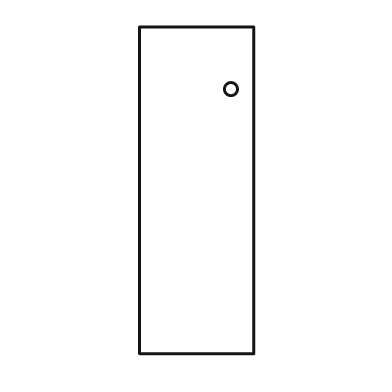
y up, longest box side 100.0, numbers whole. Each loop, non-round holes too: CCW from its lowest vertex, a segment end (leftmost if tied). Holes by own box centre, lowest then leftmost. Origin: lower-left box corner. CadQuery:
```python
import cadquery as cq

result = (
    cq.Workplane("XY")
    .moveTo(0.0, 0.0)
    .lineTo(35.0, 0.0)
    .lineTo(35.0, 100.0)
    .lineTo(0.0, 100.0)
    .close()
    .moveTo(28.0, 81.0)
    .circle(2.0)
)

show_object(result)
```